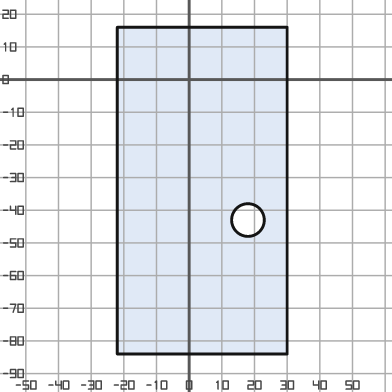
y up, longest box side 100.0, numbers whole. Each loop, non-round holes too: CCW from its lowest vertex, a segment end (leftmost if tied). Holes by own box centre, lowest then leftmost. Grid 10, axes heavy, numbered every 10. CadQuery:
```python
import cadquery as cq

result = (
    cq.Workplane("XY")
    .moveTo(-22.0, -84.0)
    .lineTo(30.0, -84.0)
    .lineTo(30.0, 16.0)
    .lineTo(-22.0, 16.0)
    .close()
    .moveTo(18.0, -43.0)
    .circle(5.0)
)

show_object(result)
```